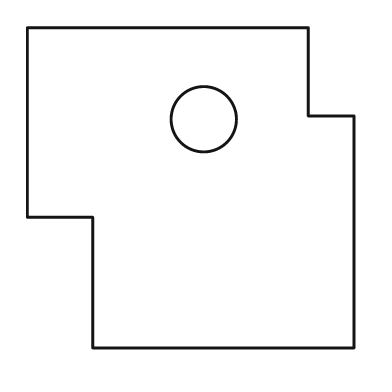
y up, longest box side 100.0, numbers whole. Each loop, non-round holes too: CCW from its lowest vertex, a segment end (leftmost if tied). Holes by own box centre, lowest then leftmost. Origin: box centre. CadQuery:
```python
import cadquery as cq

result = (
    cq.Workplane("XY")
    .moveTo(-30.0, -49.0)
    .lineTo(50.0, -49.0)
    .lineTo(50.0, 22.0)
    .lineTo(36.0, 22.0)
    .lineTo(36.0, 49.0)
    .lineTo(-50.0, 49.0)
    .lineTo(-50.0, -9.0)
    .lineTo(-30.0, -9.0)
    .close()
    .moveTo(4.0, 21.0)
    .circle(10.0)
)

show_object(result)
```